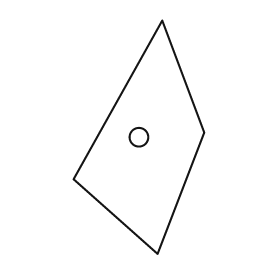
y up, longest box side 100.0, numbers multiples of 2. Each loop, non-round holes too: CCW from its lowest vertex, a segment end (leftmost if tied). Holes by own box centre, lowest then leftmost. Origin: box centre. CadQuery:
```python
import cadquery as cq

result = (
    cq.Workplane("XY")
    .moveTo(8.0, -50.0)
    .lineTo(28.0, 2.0)
    .lineTo(10.0, 50.0)
    .lineTo(-28.0, -18.0)
    .close()
    .moveTo(0.0, 0.0)
    .circle(4.0)
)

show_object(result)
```